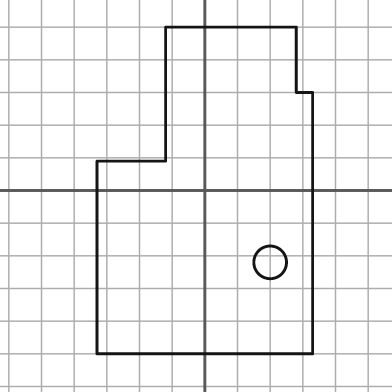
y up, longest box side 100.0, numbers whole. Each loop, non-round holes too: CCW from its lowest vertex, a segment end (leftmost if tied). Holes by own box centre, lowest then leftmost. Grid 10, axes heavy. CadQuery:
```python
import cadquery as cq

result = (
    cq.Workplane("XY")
    .moveTo(-33.0, -50.0)
    .lineTo(33.0, -50.0)
    .lineTo(33.0, 30.0)
    .lineTo(28.0, 30.0)
    .lineTo(28.0, 50.0)
    .lineTo(-12.0, 50.0)
    .lineTo(-12.0, 9.0)
    .lineTo(-33.0, 9.0)
    .close()
    .moveTo(20.0, -22.0)
    .circle(5.0)
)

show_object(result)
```